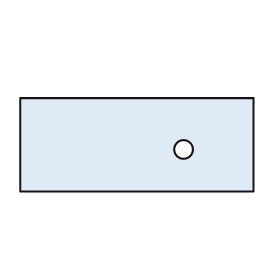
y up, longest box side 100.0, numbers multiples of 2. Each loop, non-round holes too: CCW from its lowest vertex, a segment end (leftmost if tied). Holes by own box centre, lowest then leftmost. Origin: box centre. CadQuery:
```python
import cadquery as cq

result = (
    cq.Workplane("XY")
    .moveTo(-50.0, -20.0)
    .lineTo(50.0, -20.0)
    .lineTo(50.0, 20.0)
    .lineTo(-50.0, 20.0)
    .close()
    .moveTo(20.0, -2.0)
    .circle(4.0)
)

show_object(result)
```